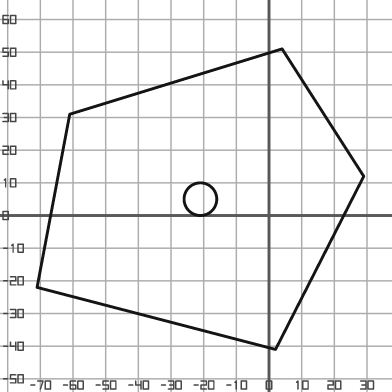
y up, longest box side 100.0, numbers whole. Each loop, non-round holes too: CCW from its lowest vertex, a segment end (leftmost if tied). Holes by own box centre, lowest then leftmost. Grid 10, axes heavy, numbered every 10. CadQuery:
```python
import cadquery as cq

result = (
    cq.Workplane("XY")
    .moveTo(2.0, -41.0)
    .lineTo(29.0, 12.0)
    .lineTo(4.0, 51.0)
    .lineTo(-61.0, 31.0)
    .lineTo(-71.0, -22.0)
    .close()
    .moveTo(-21.0, 5.0)
    .circle(5.0)
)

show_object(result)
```